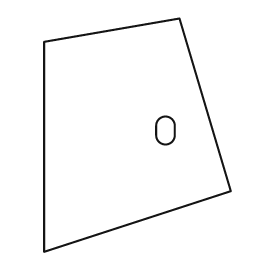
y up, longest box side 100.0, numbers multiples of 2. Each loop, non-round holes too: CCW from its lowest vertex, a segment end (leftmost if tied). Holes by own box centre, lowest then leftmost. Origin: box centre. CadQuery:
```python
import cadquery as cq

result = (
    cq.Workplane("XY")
    .moveTo(-40.0, -50.0)
    .lineTo(40.0, -24.0)
    .lineTo(18.0, 50.0)
    .lineTo(-40.0, 40.0)
    .close()
    .moveTo(8.0, 0.0)
    .threePointArc((12.0, -4.0), (16.0, 0.0))
    .lineTo(16.0, 4.0)
    .threePointArc((12.0, 8.0), (8.0, 4.0))
    .close()
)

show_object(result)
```